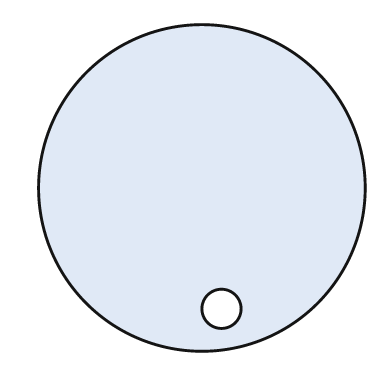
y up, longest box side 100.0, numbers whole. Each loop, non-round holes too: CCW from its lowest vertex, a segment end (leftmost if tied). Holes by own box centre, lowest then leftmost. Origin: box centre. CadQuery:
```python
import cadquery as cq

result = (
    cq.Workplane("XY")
    .moveTo(0.0, 0.0)
    .circle(50.0)
    .moveTo(6.0, -37.0)
    .circle(6.0)
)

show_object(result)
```